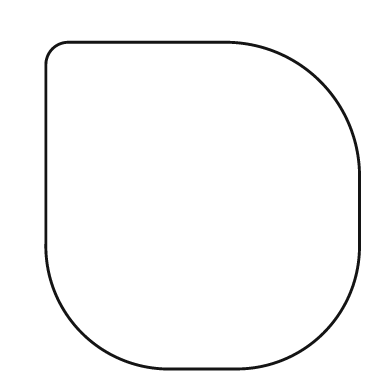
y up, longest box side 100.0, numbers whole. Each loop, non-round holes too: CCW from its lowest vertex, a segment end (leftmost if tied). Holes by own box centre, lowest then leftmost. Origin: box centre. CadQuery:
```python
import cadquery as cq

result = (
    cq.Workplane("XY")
    .moveTo(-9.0, -50.0)
    .lineTo(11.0, -50.0)
    .threePointArc((37.0, -39.0), (48.0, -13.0))
    .lineTo(48.0, 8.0)
    .threePointArc((36.0, 38.0), (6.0, 50.0))
    .lineTo(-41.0, 50.0)
    .threePointArc((-46.0, 48.0), (-48.0, 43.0))
    .lineTo(-48.0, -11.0)
    .threePointArc((-37.0, -39.0), (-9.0, -50.0))
    .close()
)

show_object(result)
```